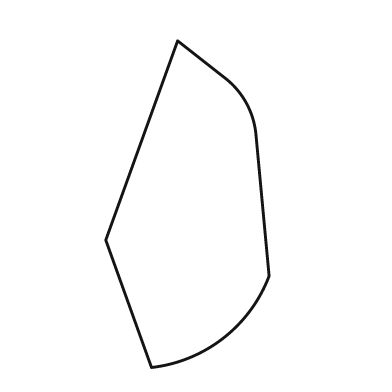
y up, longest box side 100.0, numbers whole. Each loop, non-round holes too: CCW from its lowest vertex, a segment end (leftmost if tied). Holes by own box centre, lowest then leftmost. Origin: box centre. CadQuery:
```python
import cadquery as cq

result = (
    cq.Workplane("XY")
    .moveTo(-11.0, -50.0)
    .threePointArc((11.0, -41.0), (25.0, -22.0))
    .lineTo(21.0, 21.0)
    .threePointArc((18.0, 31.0), (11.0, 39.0))
    .lineTo(-3.0, 50.0)
    .lineTo(-25.0, -11.0)
    .close()
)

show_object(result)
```